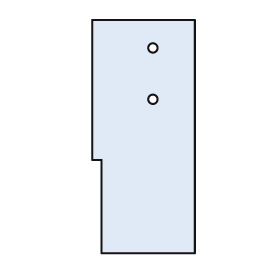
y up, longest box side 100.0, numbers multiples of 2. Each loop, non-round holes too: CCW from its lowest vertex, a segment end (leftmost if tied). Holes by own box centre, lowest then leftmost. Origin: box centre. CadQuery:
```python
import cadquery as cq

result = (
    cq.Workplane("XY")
    .moveTo(-18.0, -50.0)
    .lineTo(22.0, -50.0)
    .lineTo(22.0, 50.0)
    .lineTo(-22.0, 50.0)
    .lineTo(-22.0, -10.0)
    .lineTo(-18.0, -10.0)
    .close()
    .moveTo(4.0, 16.0)
    .circle(2.0)
    .moveTo(4.0, 38.0)
    .circle(2.0)
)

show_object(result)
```